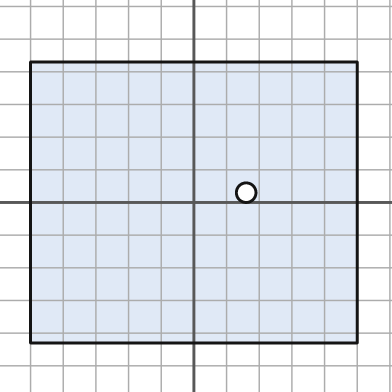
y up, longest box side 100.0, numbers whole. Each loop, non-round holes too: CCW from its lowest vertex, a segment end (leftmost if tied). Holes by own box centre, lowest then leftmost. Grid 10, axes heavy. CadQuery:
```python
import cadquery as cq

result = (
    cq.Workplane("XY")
    .moveTo(-50.0, -43.0)
    .lineTo(50.0, -43.0)
    .lineTo(50.0, 43.0)
    .lineTo(-50.0, 43.0)
    .close()
    .moveTo(16.0, 3.0)
    .circle(3.0)
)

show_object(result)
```